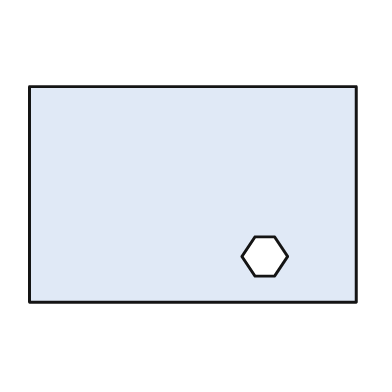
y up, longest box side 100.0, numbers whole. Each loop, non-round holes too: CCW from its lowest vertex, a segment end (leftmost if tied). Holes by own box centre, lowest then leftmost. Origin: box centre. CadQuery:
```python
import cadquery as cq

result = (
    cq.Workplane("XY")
    .moveTo(-50.0, -33.0)
    .lineTo(50.0, -33.0)
    .lineTo(50.0, 33.0)
    .lineTo(-50.0, 33.0)
    .close()
    .moveTo(19.0, -25.0)
    .lineTo(25.0, -25.0)
    .lineTo(29.0, -19.0)
    .lineTo(25.0, -13.0)
    .lineTo(19.0, -13.0)
    .lineTo(15.0, -19.0)
    .close()
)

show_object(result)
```